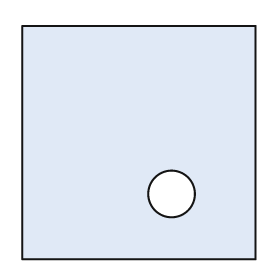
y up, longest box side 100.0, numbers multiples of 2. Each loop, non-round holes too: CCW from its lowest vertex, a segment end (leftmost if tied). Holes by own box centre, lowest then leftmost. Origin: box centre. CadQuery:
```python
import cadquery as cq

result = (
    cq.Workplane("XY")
    .moveTo(-50.0, -50.0)
    .lineTo(50.0, -50.0)
    .lineTo(50.0, 50.0)
    .lineTo(-50.0, 50.0)
    .close()
    .moveTo(14.0, -22.0)
    .circle(10.0)
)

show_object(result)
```